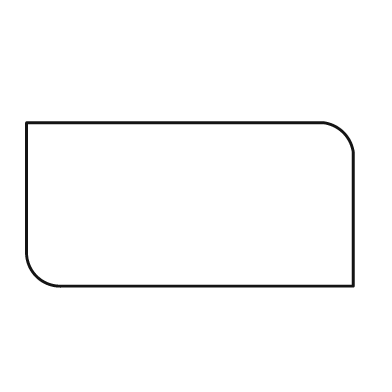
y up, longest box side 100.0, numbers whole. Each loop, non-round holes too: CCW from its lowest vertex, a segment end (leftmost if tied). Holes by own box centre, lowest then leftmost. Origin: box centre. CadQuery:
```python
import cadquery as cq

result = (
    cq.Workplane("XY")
    .moveTo(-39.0, -25.0)
    .lineTo(50.0, -25.0)
    .lineTo(50.0, 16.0)
    .threePointArc((47.0, 22.0), (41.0, 25.0))
    .lineTo(-50.0, 25.0)
    .lineTo(-50.0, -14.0)
    .threePointArc((-47.0, -22.0), (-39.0, -25.0))
    .close()
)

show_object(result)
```